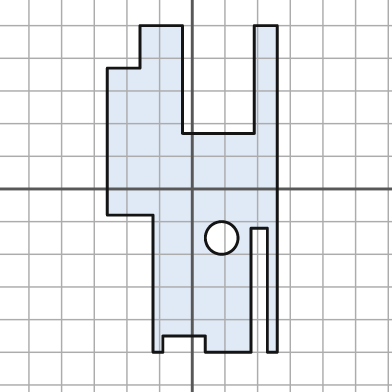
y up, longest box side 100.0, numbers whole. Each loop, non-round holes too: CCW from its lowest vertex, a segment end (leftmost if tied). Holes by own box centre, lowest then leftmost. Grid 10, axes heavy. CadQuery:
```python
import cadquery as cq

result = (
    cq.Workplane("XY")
    .moveTo(-12.0, -50.0)
    .lineTo(-9.0, -50.0)
    .lineTo(-9.0, -45.0)
    .lineTo(4.0, -45.0)
    .lineTo(4.0, -50.0)
    .lineTo(18.0, -50.0)
    .lineTo(18.0, -12.0)
    .lineTo(23.0, -12.0)
    .lineTo(23.0, -50.0)
    .lineTo(26.0, -50.0)
    .lineTo(26.0, 50.0)
    .lineTo(19.0, 50.0)
    .lineTo(19.0, 17.0)
    .lineTo(-3.0, 17.0)
    .lineTo(-3.0, 50.0)
    .lineTo(-16.0, 50.0)
    .lineTo(-16.0, 37.0)
    .lineTo(-26.0, 37.0)
    .lineTo(-26.0, -8.0)
    .lineTo(-12.0, -8.0)
    .close()
    .moveTo(9.0, -15.0)
    .circle(5.0)
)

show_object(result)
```